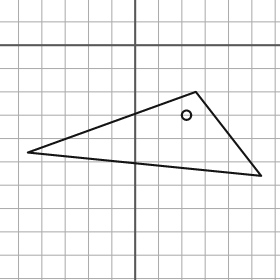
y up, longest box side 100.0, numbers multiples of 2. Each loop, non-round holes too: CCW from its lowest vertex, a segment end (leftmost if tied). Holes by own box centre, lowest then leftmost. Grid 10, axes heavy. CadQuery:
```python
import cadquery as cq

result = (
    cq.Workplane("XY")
    .moveTo(54.0, -56.0)
    .lineTo(26.0, -20.0)
    .lineTo(-46.0, -46.0)
    .close()
    .moveTo(22.0, -30.0)
    .circle(2.0)
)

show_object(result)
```